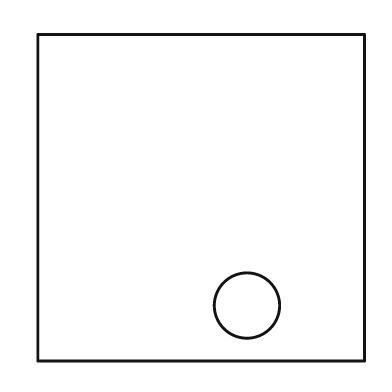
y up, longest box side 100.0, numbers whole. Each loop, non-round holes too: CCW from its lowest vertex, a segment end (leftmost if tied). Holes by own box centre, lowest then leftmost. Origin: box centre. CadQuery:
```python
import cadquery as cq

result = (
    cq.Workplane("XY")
    .moveTo(-50.0, -50.0)
    .lineTo(50.0, -50.0)
    .lineTo(50.0, 50.0)
    .lineTo(-50.0, 50.0)
    .close()
    .moveTo(14.0, -33.0)
    .circle(10.0)
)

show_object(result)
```